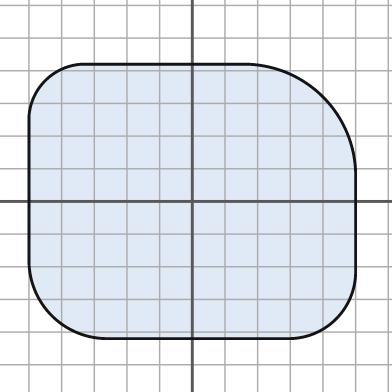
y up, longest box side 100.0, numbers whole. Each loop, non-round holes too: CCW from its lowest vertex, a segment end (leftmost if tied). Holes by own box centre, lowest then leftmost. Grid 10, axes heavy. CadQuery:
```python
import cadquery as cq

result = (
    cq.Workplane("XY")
    .moveTo(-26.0, -42.0)
    .lineTo(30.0, -42.0)
    .threePointArc((44.0, -36.0), (50.0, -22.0))
    .lineTo(50.0, 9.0)
    .threePointArc((40.0, 32.0), (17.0, 42.0))
    .lineTo(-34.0, 42.0)
    .threePointArc((-45.0, 37.0), (-50.0, 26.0))
    .lineTo(-50.0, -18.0)
    .threePointArc((-43.0, -35.0), (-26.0, -42.0))
    .close()
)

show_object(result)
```